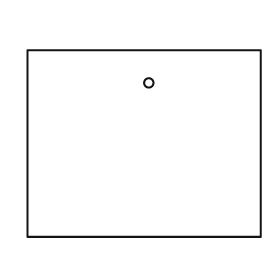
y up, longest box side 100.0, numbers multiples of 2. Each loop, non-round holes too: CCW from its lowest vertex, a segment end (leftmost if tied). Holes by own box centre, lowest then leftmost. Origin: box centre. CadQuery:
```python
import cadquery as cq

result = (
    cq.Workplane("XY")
    .moveTo(-50.0, -40.0)
    .lineTo(50.0, -40.0)
    .lineTo(50.0, 40.0)
    .lineTo(-50.0, 40.0)
    .close()
    .moveTo(2.0, 26.0)
    .circle(2.0)
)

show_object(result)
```